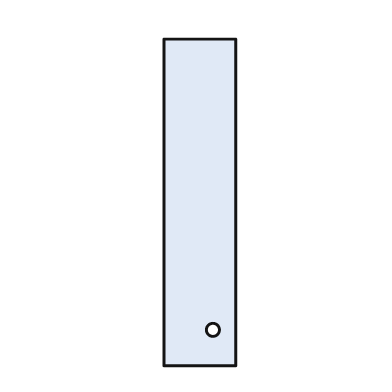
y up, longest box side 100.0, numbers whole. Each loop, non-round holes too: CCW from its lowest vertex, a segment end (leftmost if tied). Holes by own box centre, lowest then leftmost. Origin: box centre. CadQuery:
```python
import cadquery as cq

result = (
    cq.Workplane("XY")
    .moveTo(-11.0, -50.0)
    .lineTo(11.0, -50.0)
    .lineTo(11.0, 50.0)
    .lineTo(-11.0, 50.0)
    .close()
    .moveTo(4.0, -39.0)
    .circle(2.0)
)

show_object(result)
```